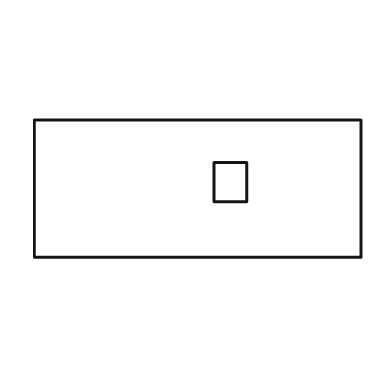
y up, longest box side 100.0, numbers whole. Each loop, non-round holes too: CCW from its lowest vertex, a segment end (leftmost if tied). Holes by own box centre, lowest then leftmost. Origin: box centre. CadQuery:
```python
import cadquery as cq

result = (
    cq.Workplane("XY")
    .moveTo(-50.0, -21.0)
    .lineTo(50.0, -21.0)
    .lineTo(50.0, 21.0)
    .lineTo(-50.0, 21.0)
    .close()
    .moveTo(5.0, -4.0)
    .lineTo(15.0, -4.0)
    .lineTo(15.0, 8.0)
    .lineTo(5.0, 8.0)
    .close()
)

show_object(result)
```